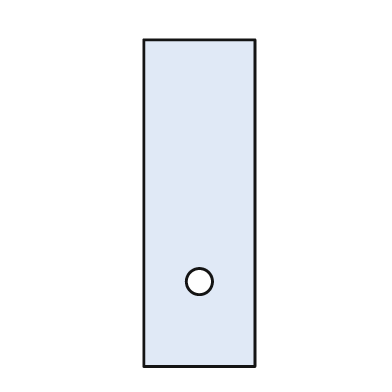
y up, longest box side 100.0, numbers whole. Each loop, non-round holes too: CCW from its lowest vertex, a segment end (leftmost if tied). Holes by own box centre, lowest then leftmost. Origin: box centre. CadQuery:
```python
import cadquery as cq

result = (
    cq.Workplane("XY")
    .moveTo(-17.0, -50.0)
    .lineTo(17.0, -50.0)
    .lineTo(17.0, 50.0)
    .lineTo(-17.0, 50.0)
    .close()
    .moveTo(0.0, -24.0)
    .circle(4.0)
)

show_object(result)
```